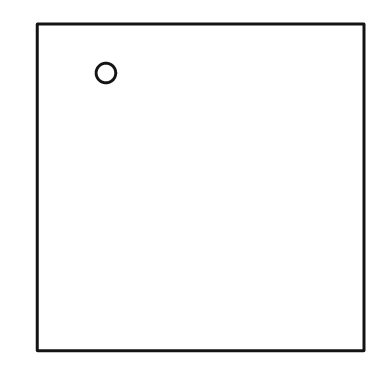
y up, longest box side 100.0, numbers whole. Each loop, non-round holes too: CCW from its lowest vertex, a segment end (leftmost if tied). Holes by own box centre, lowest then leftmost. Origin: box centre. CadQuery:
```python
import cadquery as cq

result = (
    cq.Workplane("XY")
    .moveTo(-50.0, -50.0)
    .lineTo(50.0, -50.0)
    .lineTo(50.0, 50.0)
    .lineTo(-50.0, 50.0)
    .close()
    .moveTo(-29.0, 35.0)
    .circle(3.0)
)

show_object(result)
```